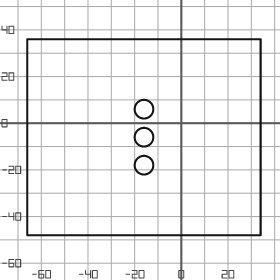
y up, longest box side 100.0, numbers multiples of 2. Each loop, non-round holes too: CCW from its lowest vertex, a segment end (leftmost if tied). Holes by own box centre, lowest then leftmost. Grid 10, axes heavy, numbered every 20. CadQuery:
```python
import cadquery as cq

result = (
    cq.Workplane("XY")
    .moveTo(-66.0, -48.0)
    .lineTo(34.0, -48.0)
    .lineTo(34.0, 36.0)
    .lineTo(-66.0, 36.0)
    .close()
    .moveTo(-16.0, -18.0)
    .circle(4.0)
    .moveTo(-16.0, -6.0)
    .circle(4.0)
    .moveTo(-16.0, 6.0)
    .circle(4.0)
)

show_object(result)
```